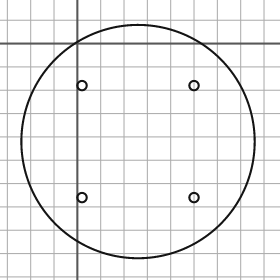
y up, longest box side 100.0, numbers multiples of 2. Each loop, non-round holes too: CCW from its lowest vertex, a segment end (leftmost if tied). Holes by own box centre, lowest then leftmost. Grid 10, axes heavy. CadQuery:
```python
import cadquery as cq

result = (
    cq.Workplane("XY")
    .moveTo(26.0, -42.0)
    .circle(50.0)
    .moveTo(2.0, -66.0)
    .circle(2.0)
    .moveTo(50.0, -66.0)
    .circle(2.0)
    .moveTo(2.0, -18.0)
    .circle(2.0)
    .moveTo(50.0, -18.0)
    .circle(2.0)
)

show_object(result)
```